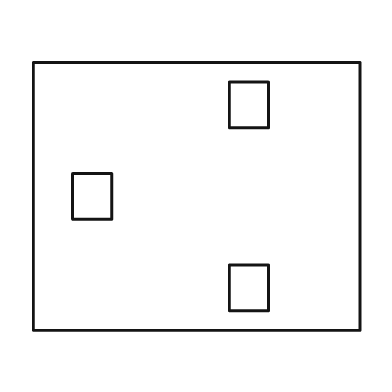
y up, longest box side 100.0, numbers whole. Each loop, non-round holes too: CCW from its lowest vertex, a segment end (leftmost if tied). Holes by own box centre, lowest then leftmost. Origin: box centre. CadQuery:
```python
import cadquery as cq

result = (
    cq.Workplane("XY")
    .moveTo(-50.0, -41.0)
    .lineTo(50.0, -41.0)
    .lineTo(50.0, 41.0)
    .lineTo(-50.0, 41.0)
    .close()
    .moveTo(10.0, -35.0)
    .lineTo(22.0, -35.0)
    .lineTo(22.0, -21.0)
    .lineTo(10.0, -21.0)
    .close()
    .moveTo(-38.0, -7.0)
    .lineTo(-26.0, -7.0)
    .lineTo(-26.0, 7.0)
    .lineTo(-38.0, 7.0)
    .close()
    .moveTo(10.0, 21.0)
    .lineTo(22.0, 21.0)
    .lineTo(22.0, 35.0)
    .lineTo(10.0, 35.0)
    .close()
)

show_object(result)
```